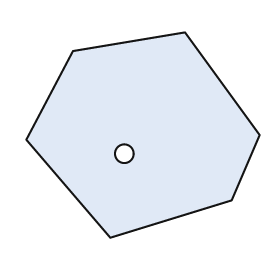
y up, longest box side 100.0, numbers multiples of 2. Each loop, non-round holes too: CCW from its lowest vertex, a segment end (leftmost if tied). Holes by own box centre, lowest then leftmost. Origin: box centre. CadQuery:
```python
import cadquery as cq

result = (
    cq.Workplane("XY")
    .moveTo(-14.0, -44.0)
    .lineTo(38.0, -28.0)
    .lineTo(50.0, 0.0)
    .lineTo(18.0, 44.0)
    .lineTo(-30.0, 36.0)
    .lineTo(-50.0, -2.0)
    .close()
    .moveTo(-8.0, -8.0)
    .circle(4.0)
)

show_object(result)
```